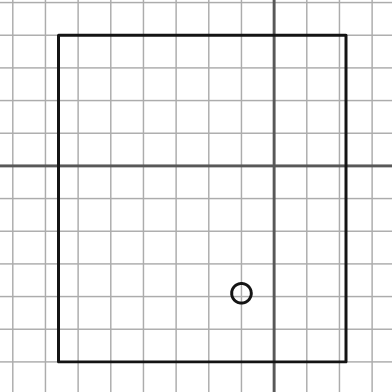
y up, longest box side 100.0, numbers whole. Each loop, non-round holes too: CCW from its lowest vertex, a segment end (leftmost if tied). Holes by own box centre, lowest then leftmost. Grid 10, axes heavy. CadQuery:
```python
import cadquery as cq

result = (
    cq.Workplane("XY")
    .moveTo(-66.0, -60.0)
    .lineTo(22.0, -60.0)
    .lineTo(22.0, 40.0)
    .lineTo(-66.0, 40.0)
    .close()
    .moveTo(-10.0, -39.0)
    .circle(3.0)
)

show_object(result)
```